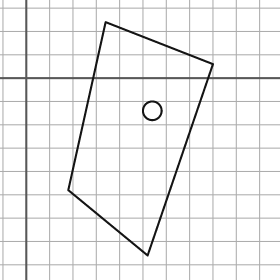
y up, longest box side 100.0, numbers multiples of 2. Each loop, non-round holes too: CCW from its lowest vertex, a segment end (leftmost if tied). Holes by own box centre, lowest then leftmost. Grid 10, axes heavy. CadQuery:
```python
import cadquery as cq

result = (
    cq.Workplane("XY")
    .moveTo(52.0, -76.0)
    .lineTo(80.0, 6.0)
    .lineTo(34.0, 24.0)
    .lineTo(18.0, -48.0)
    .close()
    .moveTo(54.0, -14.0)
    .circle(4.0)
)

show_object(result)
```